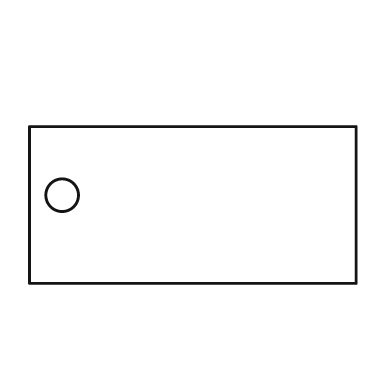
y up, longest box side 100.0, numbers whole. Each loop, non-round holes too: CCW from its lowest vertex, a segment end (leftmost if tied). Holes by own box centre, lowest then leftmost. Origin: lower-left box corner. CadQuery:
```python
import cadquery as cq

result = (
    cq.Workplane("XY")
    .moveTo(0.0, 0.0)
    .lineTo(100.0, 0.0)
    .lineTo(100.0, 48.0)
    .lineTo(0.0, 48.0)
    .close()
    .moveTo(10.0, 27.0)
    .circle(5.0)
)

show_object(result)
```